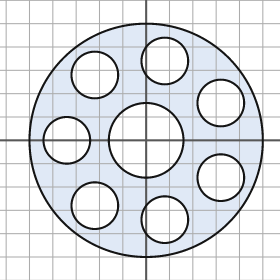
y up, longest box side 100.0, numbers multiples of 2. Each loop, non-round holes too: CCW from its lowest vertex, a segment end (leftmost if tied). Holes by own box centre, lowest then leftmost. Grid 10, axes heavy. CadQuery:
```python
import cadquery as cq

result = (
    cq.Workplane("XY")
    .moveTo(0.0, 0.0)
    .circle(50.0)
    .moveTo(8.0, -34.0)
    .circle(10.0)
    .moveTo(-22.0, -28.0)
    .circle(10.0)
    .moveTo(32.0, -16.0)
    .circle(10.0)
    .moveTo(-34.0, 0.0)
    .circle(10.0)
    .moveTo(0.0, 0.0)
    .circle(16.0)
    .moveTo(32.0, 16.0)
    .circle(10.0)
    .moveTo(-22.0, 28.0)
    .circle(10.0)
    .moveTo(8.0, 34.0)
    .circle(10.0)
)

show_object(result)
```